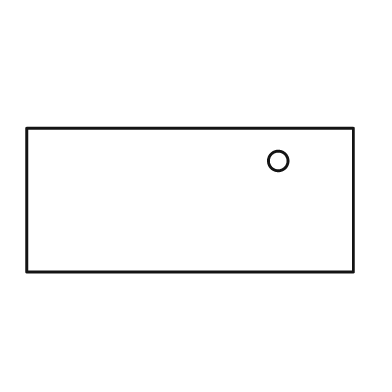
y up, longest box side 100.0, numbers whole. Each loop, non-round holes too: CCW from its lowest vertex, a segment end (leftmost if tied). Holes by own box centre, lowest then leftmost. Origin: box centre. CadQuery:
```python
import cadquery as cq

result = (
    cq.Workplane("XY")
    .moveTo(-50.0, -22.0)
    .lineTo(50.0, -22.0)
    .lineTo(50.0, 22.0)
    .lineTo(-50.0, 22.0)
    .close()
    .moveTo(27.0, 12.0)
    .circle(3.0)
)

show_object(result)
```